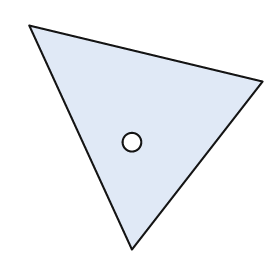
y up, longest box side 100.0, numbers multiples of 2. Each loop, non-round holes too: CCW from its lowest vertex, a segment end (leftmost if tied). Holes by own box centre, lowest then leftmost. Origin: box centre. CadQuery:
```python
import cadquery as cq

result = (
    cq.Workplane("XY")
    .moveTo(-6.0, -48.0)
    .lineTo(50.0, 24.0)
    .lineTo(-50.0, 48.0)
    .close()
    .moveTo(-6.0, -2.0)
    .circle(4.0)
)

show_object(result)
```